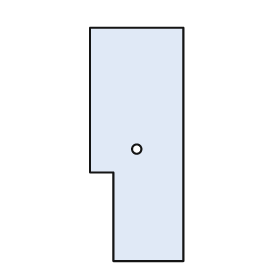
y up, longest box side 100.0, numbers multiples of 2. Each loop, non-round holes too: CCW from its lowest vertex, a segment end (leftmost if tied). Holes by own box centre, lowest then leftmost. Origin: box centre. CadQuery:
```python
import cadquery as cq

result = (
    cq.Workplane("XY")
    .moveTo(-10.0, -50.0)
    .lineTo(20.0, -50.0)
    .lineTo(20.0, 50.0)
    .lineTo(-20.0, 50.0)
    .lineTo(-20.0, -12.0)
    .lineTo(-10.0, -12.0)
    .close()
    .moveTo(0.0, -2.0)
    .circle(2.0)
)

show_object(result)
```